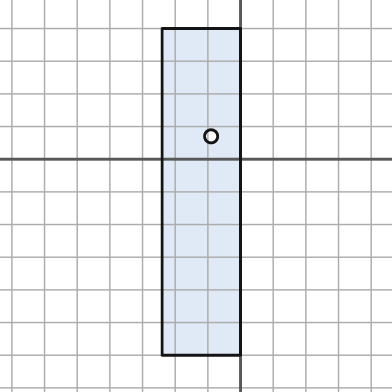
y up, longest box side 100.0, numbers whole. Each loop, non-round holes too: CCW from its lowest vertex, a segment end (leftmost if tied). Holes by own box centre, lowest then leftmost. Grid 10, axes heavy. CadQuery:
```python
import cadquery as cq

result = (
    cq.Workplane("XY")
    .moveTo(-24.0, -60.0)
    .lineTo(0.0, -60.0)
    .lineTo(0.0, 40.0)
    .lineTo(-24.0, 40.0)
    .close()
    .moveTo(-9.0, 7.0)
    .circle(2.0)
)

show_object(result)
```